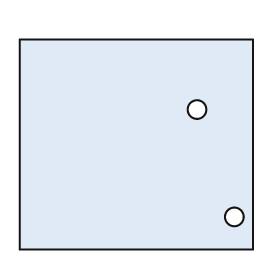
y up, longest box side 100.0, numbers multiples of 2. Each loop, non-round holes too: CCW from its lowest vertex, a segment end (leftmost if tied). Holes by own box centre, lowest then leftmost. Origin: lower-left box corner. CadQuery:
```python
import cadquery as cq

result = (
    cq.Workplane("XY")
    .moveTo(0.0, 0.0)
    .lineTo(100.0, 0.0)
    .lineTo(100.0, 90.0)
    .lineTo(0.0, 90.0)
    .close()
    .moveTo(92.0, 14.0)
    .circle(4.0)
    .moveTo(76.0, 60.0)
    .circle(4.0)
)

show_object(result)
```